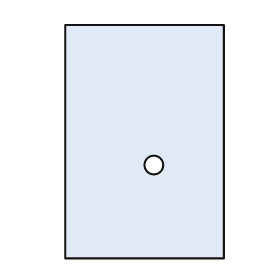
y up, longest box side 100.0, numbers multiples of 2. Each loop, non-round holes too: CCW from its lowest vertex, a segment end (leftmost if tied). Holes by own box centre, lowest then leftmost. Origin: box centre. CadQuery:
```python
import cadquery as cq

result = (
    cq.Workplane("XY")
    .moveTo(-34.0, -50.0)
    .lineTo(34.0, -50.0)
    .lineTo(34.0, 50.0)
    .lineTo(-34.0, 50.0)
    .close()
    .moveTo(4.0, -10.0)
    .circle(4.0)
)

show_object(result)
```